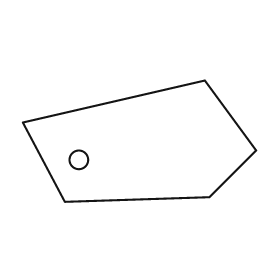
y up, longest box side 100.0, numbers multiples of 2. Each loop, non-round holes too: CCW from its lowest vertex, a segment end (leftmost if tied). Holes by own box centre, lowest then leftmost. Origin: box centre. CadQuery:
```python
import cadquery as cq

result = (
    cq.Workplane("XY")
    .moveTo(-32.0, -26.0)
    .lineTo(30.0, -24.0)
    .lineTo(50.0, -4.0)
    .lineTo(28.0, 26.0)
    .lineTo(-50.0, 8.0)
    .close()
    .moveTo(-26.0, -8.0)
    .circle(4.0)
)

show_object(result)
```